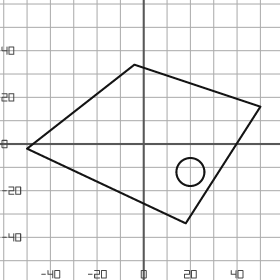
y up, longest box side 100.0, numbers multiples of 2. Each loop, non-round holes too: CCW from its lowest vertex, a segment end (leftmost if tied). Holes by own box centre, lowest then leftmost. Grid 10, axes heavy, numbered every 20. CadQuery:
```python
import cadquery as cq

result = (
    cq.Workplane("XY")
    .moveTo(18.0, -34.0)
    .lineTo(50.0, 16.0)
    .lineTo(-4.0, 34.0)
    .lineTo(-50.0, -2.0)
    .close()
    .moveTo(20.0, -12.0)
    .circle(6.0)
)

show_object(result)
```